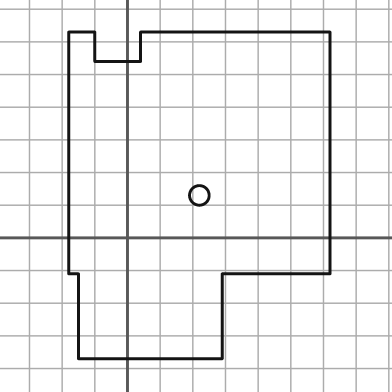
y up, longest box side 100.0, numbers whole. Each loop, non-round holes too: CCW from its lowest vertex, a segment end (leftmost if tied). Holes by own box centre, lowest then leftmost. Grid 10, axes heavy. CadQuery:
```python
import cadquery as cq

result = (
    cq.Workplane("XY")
    .moveTo(-15.0, -37.0)
    .lineTo(29.0, -37.0)
    .lineTo(29.0, -11.0)
    .lineTo(62.0, -11.0)
    .lineTo(62.0, 63.0)
    .lineTo(4.0, 63.0)
    .lineTo(4.0, 54.0)
    .lineTo(-10.0, 54.0)
    .lineTo(-10.0, 63.0)
    .lineTo(-18.0, 63.0)
    .lineTo(-18.0, -11.0)
    .lineTo(-15.0, -11.0)
    .close()
    .moveTo(22.0, 13.0)
    .circle(3.0)
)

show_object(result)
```